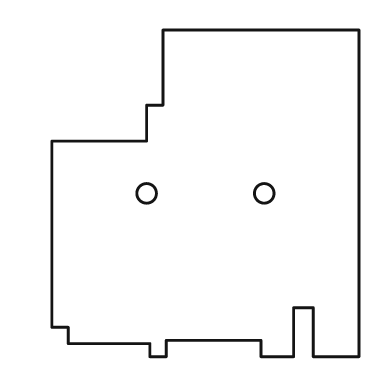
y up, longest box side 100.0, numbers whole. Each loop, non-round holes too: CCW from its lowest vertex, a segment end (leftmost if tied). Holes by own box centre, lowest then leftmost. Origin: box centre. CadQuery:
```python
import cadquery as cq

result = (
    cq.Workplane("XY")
    .moveTo(-17.0, -50.0)
    .lineTo(-12.0, -50.0)
    .lineTo(-12.0, -45.0)
    .lineTo(17.0, -45.0)
    .lineTo(17.0, -50.0)
    .lineTo(27.0, -50.0)
    .lineTo(27.0, -35.0)
    .lineTo(33.0, -35.0)
    .lineTo(33.0, -50.0)
    .lineTo(47.0, -50.0)
    .lineTo(47.0, 50.0)
    .lineTo(-13.0, 50.0)
    .lineTo(-13.0, 27.0)
    .lineTo(-18.0, 27.0)
    .lineTo(-18.0, 16.0)
    .lineTo(-47.0, 16.0)
    .lineTo(-47.0, -41.0)
    .lineTo(-42.0, -41.0)
    .lineTo(-42.0, -46.0)
    .lineTo(-17.0, -46.0)
    .close()
    .moveTo(-18.0, 0.0)
    .circle(3.0)
    .moveTo(18.0, 0.0)
    .circle(3.0)
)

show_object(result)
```